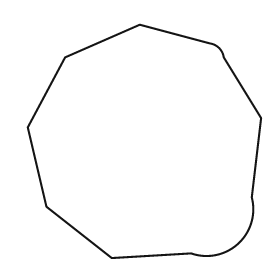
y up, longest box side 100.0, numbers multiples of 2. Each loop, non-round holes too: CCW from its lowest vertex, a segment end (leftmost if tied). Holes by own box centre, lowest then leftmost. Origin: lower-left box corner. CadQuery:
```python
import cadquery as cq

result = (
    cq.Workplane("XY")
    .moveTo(36.0, 0.0)
    .lineTo(70.0, 2.0)
    .threePointArc((90.0, 6.0), (96.0, 26.0))
    .lineTo(100.0, 60.0)
    .lineTo(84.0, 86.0)
    .threePointArc((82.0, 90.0), (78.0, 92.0))
    .lineTo(48.0, 100.0)
    .lineTo(16.0, 86.0)
    .lineTo(0.0, 56.0)
    .lineTo(8.0, 22.0)
    .close()
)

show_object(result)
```